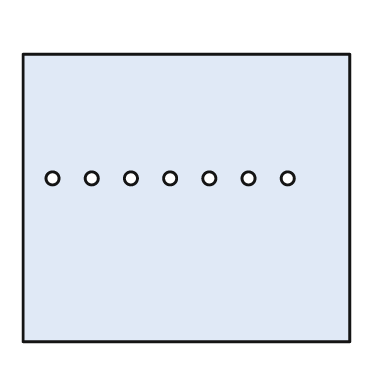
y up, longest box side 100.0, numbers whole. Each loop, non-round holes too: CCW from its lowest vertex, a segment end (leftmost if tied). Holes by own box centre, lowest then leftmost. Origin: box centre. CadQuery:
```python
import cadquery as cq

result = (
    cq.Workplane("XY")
    .moveTo(-50.0, -44.0)
    .lineTo(50.0, -44.0)
    .lineTo(50.0, 44.0)
    .lineTo(-50.0, 44.0)
    .close()
    .moveTo(-41.0, 6.0)
    .circle(2.0)
    .moveTo(-29.0, 6.0)
    .circle(2.0)
    .moveTo(-17.0, 6.0)
    .circle(2.0)
    .moveTo(-5.0, 6.0)
    .circle(2.0)
    .moveTo(7.0, 6.0)
    .circle(2.0)
    .moveTo(19.0, 6.0)
    .circle(2.0)
    .moveTo(31.0, 6.0)
    .circle(2.0)
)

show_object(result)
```